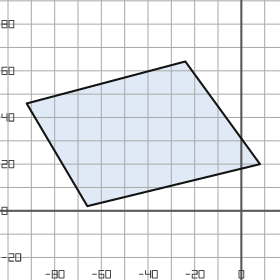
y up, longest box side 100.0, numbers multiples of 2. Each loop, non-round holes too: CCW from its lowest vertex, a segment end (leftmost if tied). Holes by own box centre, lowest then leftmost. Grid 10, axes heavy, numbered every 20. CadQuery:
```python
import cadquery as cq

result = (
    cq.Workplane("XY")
    .moveTo(-66.0, 2.0)
    .lineTo(8.0, 20.0)
    .lineTo(-24.0, 64.0)
    .lineTo(-92.0, 46.0)
    .close()
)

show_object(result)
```